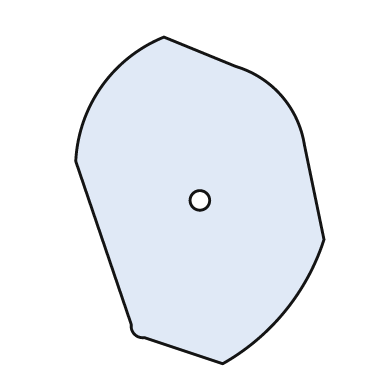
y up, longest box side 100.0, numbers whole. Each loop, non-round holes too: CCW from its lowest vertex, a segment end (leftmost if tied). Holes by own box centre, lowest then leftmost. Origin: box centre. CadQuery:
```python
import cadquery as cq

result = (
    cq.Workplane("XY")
    .moveTo(7.0, -50.0)
    .threePointArc((26.0, -34.0), (38.0, -12.0))
    .lineTo(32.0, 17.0)
    .threePointArc((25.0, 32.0), (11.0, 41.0))
    .lineTo(-11.0, 50.0)
    .threePointArc((-30.0, 35.0), (-38.0, 12.0))
    .lineTo(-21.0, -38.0)
    .threePointArc((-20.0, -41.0), (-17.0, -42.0))
    .close()
    .moveTo(0.0, 0.0)
    .circle(3.0)
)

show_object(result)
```